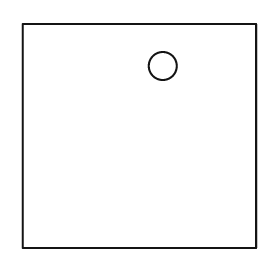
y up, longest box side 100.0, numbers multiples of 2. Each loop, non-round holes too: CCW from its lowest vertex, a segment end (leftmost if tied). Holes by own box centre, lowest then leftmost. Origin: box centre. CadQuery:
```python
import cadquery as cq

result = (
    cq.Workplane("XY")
    .moveTo(-50.0, -48.0)
    .lineTo(50.0, -48.0)
    .lineTo(50.0, 48.0)
    .lineTo(-50.0, 48.0)
    .close()
    .moveTo(10.0, 30.0)
    .circle(6.0)
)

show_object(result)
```